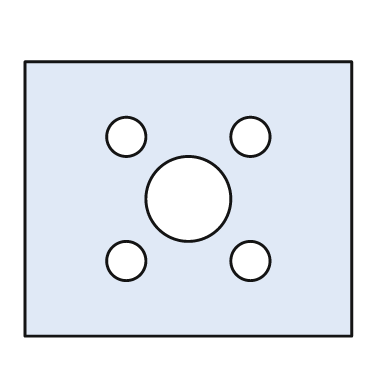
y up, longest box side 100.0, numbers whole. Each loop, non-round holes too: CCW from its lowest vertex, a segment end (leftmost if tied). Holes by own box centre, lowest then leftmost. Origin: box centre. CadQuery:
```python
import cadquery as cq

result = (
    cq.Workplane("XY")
    .moveTo(-50.0, -42.0)
    .lineTo(50.0, -42.0)
    .lineTo(50.0, 42.0)
    .lineTo(-50.0, 42.0)
    .close()
    .moveTo(-19.0, -19.0)
    .circle(6.0)
    .moveTo(19.0, -19.0)
    .circle(6.0)
    .moveTo(0.0, 0.0)
    .circle(13.0)
    .moveTo(-19.0, 19.0)
    .circle(6.0)
    .moveTo(19.0, 19.0)
    .circle(6.0)
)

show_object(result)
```